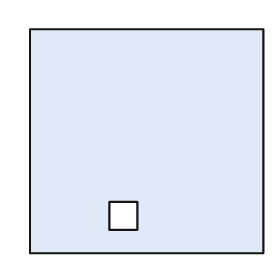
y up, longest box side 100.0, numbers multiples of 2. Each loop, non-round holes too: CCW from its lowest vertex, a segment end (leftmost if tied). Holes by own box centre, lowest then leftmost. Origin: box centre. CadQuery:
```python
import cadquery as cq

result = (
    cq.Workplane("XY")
    .moveTo(-50.0, -48.0)
    .lineTo(50.0, -48.0)
    .lineTo(50.0, 48.0)
    .lineTo(-50.0, 48.0)
    .close()
    .moveTo(-16.0, -38.0)
    .lineTo(-4.0, -38.0)
    .lineTo(-4.0, -26.0)
    .lineTo(-16.0, -26.0)
    .close()
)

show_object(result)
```